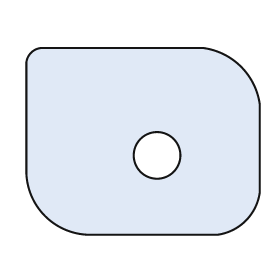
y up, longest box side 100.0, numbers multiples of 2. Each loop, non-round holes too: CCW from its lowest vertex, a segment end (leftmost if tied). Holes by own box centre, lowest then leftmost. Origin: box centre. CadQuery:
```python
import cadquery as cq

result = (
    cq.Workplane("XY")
    .moveTo(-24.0, -40.0)
    .lineTo(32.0, -40.0)
    .threePointArc((44.0, -34.0), (50.0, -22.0))
    .lineTo(50.0, 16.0)
    .threePointArc((42.0, 32.0), (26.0, 40.0))
    .lineTo(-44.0, 40.0)
    .threePointArc((-48.0, 38.0), (-50.0, 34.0))
    .lineTo(-50.0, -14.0)
    .threePointArc((-42.0, -32.0), (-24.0, -40.0))
    .close()
    .moveTo(6.0, -6.0)
    .circle(10.0)
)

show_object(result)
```